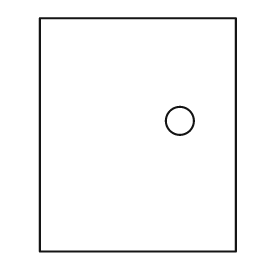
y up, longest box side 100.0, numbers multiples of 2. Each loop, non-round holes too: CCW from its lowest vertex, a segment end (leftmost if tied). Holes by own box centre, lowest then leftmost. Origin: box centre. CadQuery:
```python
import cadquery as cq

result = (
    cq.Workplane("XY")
    .moveTo(-42.0, -50.0)
    .lineTo(42.0, -50.0)
    .lineTo(42.0, 50.0)
    .lineTo(-42.0, 50.0)
    .close()
    .moveTo(18.0, 6.0)
    .circle(6.0)
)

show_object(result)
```